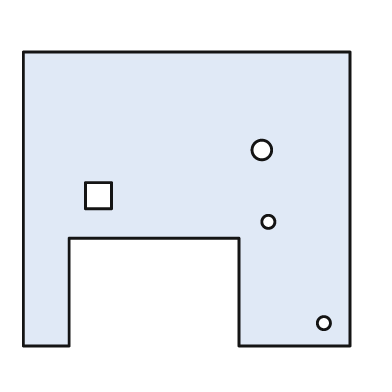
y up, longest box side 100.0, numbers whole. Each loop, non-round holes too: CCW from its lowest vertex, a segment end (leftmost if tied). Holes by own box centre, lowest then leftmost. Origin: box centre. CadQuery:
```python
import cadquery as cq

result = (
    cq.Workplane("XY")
    .moveTo(-50.0, -45.0)
    .lineTo(-36.0, -45.0)
    .lineTo(-36.0, -12.0)
    .lineTo(16.0, -12.0)
    .lineTo(16.0, -45.0)
    .lineTo(50.0, -45.0)
    .lineTo(50.0, 45.0)
    .lineTo(-50.0, 45.0)
    .close()
    .moveTo(42.0, -38.0)
    .circle(2.0)
    .moveTo(25.0, -7.0)
    .circle(2.0)
    .moveTo(-31.0, -3.0)
    .lineTo(-23.0, -3.0)
    .lineTo(-23.0, 5.0)
    .lineTo(-31.0, 5.0)
    .close()
    .moveTo(23.0, 15.0)
    .circle(3.0)
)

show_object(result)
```